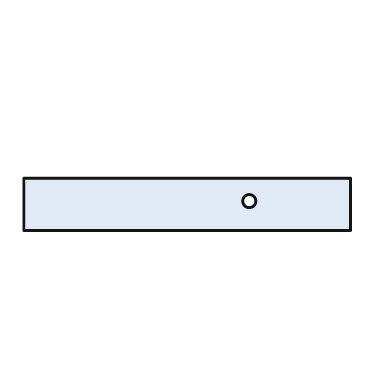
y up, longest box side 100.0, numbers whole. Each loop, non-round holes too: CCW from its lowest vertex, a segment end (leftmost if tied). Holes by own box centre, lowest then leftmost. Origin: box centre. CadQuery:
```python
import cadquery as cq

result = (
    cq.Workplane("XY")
    .moveTo(-50.0, -8.0)
    .lineTo(50.0, -8.0)
    .lineTo(50.0, 8.0)
    .lineTo(-50.0, 8.0)
    .close()
    .moveTo(19.0, 1.0)
    .circle(2.0)
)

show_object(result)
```